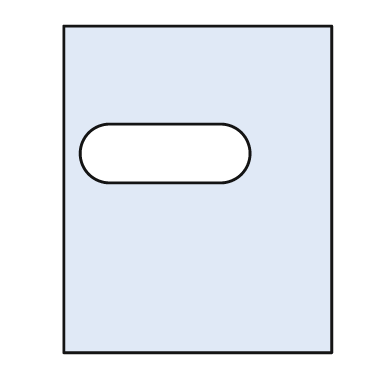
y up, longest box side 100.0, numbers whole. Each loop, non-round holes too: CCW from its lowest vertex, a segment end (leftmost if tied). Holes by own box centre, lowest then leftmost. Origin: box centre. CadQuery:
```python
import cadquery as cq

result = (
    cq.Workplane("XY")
    .moveTo(-41.0, -50.0)
    .lineTo(41.0, -50.0)
    .lineTo(41.0, 50.0)
    .lineTo(-41.0, 50.0)
    .close()
    .moveTo(-27.0, 2.0)
    .lineTo(7.0, 2.0)
    .threePointArc((16.0, 11.0), (7.0, 20.0))
    .lineTo(-27.0, 20.0)
    .threePointArc((-36.0, 11.0), (-27.0, 2.0))
    .close()
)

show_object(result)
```